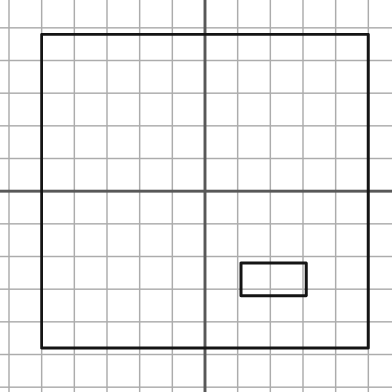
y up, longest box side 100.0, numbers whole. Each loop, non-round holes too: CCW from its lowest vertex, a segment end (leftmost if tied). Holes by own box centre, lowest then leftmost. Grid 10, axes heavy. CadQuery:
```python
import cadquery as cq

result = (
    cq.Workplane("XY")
    .moveTo(-50.0, -48.0)
    .lineTo(50.0, -48.0)
    .lineTo(50.0, 48.0)
    .lineTo(-50.0, 48.0)
    .close()
    .moveTo(11.0, -32.0)
    .lineTo(31.0, -32.0)
    .lineTo(31.0, -22.0)
    .lineTo(11.0, -22.0)
    .close()
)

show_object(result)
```